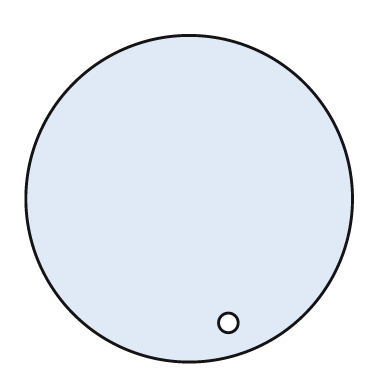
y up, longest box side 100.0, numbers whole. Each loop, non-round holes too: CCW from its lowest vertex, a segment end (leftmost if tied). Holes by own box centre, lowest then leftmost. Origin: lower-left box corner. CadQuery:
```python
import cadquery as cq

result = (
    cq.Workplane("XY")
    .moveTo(50.0, 50.0)
    .circle(50.0)
    .moveTo(62.0, 12.0)
    .circle(3.0)
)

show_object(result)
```